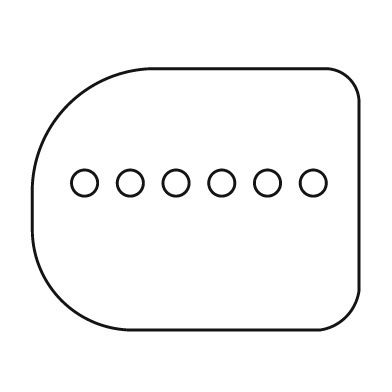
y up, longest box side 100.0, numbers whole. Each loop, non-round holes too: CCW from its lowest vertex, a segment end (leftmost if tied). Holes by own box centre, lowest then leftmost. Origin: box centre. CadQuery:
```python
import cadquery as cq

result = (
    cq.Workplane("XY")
    .moveTo(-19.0, -40.0)
    .lineTo(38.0, -40.0)
    .threePointArc((46.0, -36.0), (50.0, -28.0))
    .lineTo(50.0, 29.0)
    .threePointArc((47.0, 37.0), (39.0, 40.0))
    .lineTo(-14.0, 40.0)
    .threePointArc((-39.0, 29.0), (-50.0, 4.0))
    .lineTo(-50.0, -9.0)
    .threePointArc((-41.0, -31.0), (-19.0, -40.0))
    .close()
    .moveTo(-34.0, 5.0)
    .circle(4.0)
    .moveTo(-20.0, 5.0)
    .circle(4.0)
    .moveTo(-6.0, 5.0)
    .circle(4.0)
    .moveTo(8.0, 5.0)
    .circle(4.0)
    .moveTo(22.0, 5.0)
    .circle(4.0)
    .moveTo(36.0, 5.0)
    .circle(4.0)
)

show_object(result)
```